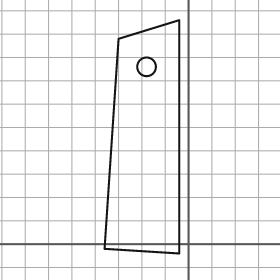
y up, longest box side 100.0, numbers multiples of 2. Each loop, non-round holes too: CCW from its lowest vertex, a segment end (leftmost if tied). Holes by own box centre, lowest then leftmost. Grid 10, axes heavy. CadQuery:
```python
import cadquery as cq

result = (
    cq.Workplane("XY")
    .moveTo(-4.0, -4.0)
    .lineTo(-4.0, 96.0)
    .lineTo(-30.0, 88.0)
    .lineTo(-36.0, -2.0)
    .close()
    .moveTo(-18.0, 76.0)
    .circle(4.0)
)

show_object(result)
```